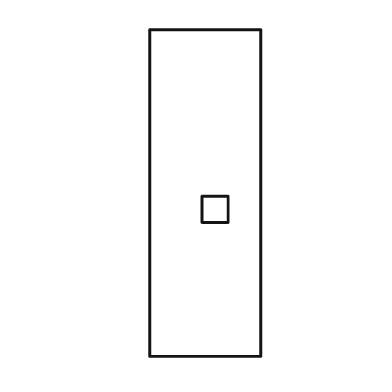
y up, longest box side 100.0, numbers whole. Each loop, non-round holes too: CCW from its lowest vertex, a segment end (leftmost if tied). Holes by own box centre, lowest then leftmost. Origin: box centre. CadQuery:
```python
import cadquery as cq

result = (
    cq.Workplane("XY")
    .moveTo(-17.0, -50.0)
    .lineTo(17.0, -50.0)
    .lineTo(17.0, 50.0)
    .lineTo(-17.0, 50.0)
    .close()
    .moveTo(-1.0, -9.0)
    .lineTo(7.0, -9.0)
    .lineTo(7.0, -1.0)
    .lineTo(-1.0, -1.0)
    .close()
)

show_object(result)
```